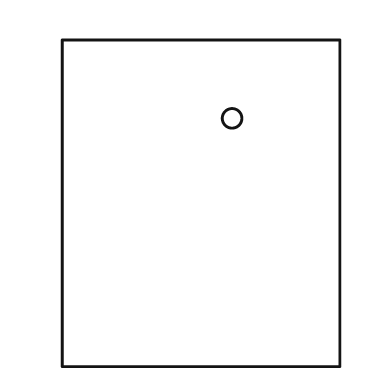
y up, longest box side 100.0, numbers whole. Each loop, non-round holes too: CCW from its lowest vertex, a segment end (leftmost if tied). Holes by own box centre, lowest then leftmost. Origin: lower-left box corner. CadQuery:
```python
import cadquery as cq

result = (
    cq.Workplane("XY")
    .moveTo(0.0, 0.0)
    .lineTo(85.0, 0.0)
    .lineTo(85.0, 100.0)
    .lineTo(0.0, 100.0)
    .close()
    .moveTo(52.0, 76.0)
    .circle(3.0)
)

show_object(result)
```